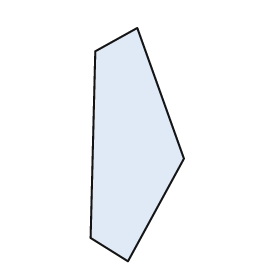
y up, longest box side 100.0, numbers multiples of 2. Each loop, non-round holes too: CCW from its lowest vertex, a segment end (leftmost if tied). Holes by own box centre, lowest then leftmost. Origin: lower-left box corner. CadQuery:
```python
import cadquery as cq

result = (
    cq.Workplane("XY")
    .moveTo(16.0, 0.0)
    .lineTo(40.0, 44.0)
    .lineTo(20.0, 100.0)
    .lineTo(2.0, 90.0)
    .lineTo(0.0, 10.0)
    .close()
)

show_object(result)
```